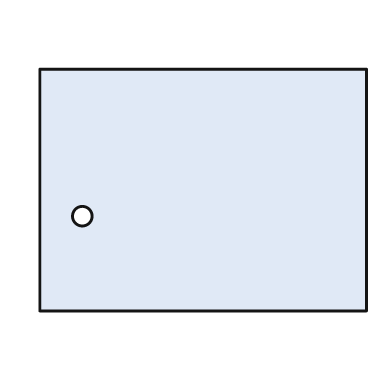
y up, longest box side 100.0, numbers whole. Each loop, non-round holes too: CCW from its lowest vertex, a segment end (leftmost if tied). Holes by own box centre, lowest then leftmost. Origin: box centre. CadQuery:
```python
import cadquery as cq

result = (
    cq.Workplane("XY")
    .moveTo(-50.0, -37.0)
    .lineTo(50.0, -37.0)
    .lineTo(50.0, 37.0)
    .lineTo(-50.0, 37.0)
    .close()
    .moveTo(-37.0, -8.0)
    .circle(3.0)
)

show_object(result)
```